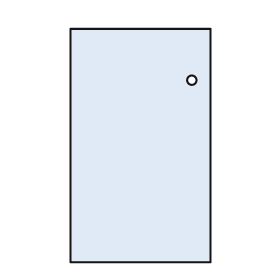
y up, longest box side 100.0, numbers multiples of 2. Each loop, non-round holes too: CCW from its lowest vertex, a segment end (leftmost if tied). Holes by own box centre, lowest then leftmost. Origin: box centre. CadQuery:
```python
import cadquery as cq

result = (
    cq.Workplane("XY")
    .moveTo(-30.0, -50.0)
    .lineTo(30.0, -50.0)
    .lineTo(30.0, 50.0)
    .lineTo(-30.0, 50.0)
    .close()
    .moveTo(22.0, 28.0)
    .circle(2.0)
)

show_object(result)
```